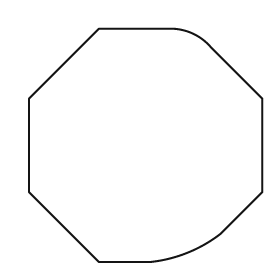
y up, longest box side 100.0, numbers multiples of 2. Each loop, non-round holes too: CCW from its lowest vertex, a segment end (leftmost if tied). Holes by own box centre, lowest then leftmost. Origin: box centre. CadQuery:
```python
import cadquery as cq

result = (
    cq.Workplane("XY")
    .moveTo(-20.0, -50.0)
    .lineTo(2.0, -50.0)
    .threePointArc((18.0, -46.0), (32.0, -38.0))
    .lineTo(50.0, -20.0)
    .lineTo(50.0, 20.0)
    .lineTo(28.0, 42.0)
    .threePointArc((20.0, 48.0), (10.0, 50.0))
    .lineTo(-20.0, 50.0)
    .lineTo(-50.0, 20.0)
    .lineTo(-50.0, -20.0)
    .close()
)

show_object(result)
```